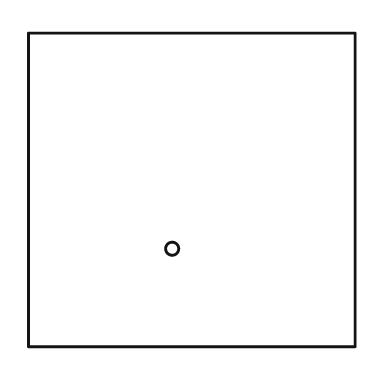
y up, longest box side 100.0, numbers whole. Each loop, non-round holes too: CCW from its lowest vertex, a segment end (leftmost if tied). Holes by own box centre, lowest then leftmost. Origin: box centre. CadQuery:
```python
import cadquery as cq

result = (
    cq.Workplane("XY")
    .moveTo(-50.0, -48.0)
    .lineTo(50.0, -48.0)
    .lineTo(50.0, 48.0)
    .lineTo(-50.0, 48.0)
    .close()
    .moveTo(-6.0, -18.0)
    .circle(2.0)
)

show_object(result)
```